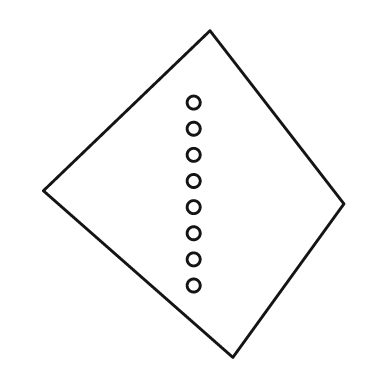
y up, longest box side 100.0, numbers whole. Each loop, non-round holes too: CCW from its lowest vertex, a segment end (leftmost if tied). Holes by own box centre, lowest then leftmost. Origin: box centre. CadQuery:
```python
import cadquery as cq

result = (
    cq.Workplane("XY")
    .moveTo(12.0, -50.0)
    .lineTo(46.0, -3.0)
    .lineTo(5.0, 50.0)
    .lineTo(-46.0, 1.0)
    .close()
    .moveTo(0.0, -28.0)
    .circle(2.0)
    .moveTo(0.0, -20.0)
    .circle(2.0)
    .moveTo(0.0, -12.0)
    .circle(2.0)
    .moveTo(0.0, -4.0)
    .circle(2.0)
    .moveTo(0.0, 4.0)
    .circle(2.0)
    .moveTo(0.0, 12.0)
    .circle(2.0)
    .moveTo(0.0, 20.0)
    .circle(2.0)
    .moveTo(0.0, 28.0)
    .circle(2.0)
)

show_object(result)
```